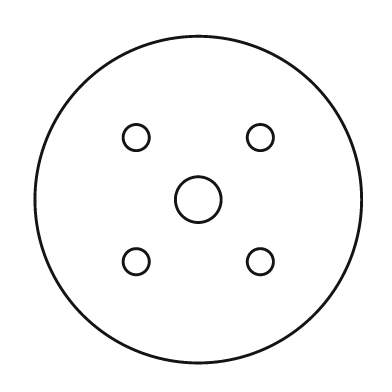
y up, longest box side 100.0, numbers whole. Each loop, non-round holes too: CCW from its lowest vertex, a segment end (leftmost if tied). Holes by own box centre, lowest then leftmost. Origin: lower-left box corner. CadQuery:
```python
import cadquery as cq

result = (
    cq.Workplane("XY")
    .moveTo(50.0, 50.0)
    .circle(50.0)
    .moveTo(31.0, 31.0)
    .circle(4.0)
    .moveTo(69.0, 31.0)
    .circle(4.0)
    .moveTo(50.0, 50.0)
    .circle(7.0)
    .moveTo(31.0, 69.0)
    .circle(4.0)
    .moveTo(69.0, 69.0)
    .circle(4.0)
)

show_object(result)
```